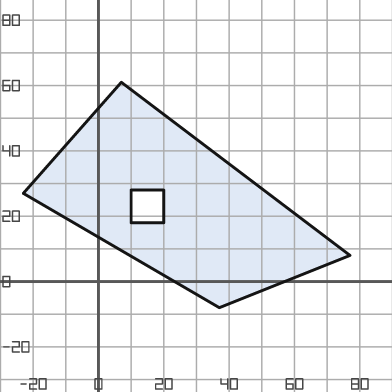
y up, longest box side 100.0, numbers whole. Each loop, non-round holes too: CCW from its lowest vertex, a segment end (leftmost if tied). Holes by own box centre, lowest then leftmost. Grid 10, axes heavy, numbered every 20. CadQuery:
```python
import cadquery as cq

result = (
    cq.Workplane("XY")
    .moveTo(37.0, -8.0)
    .lineTo(77.0, 8.0)
    .lineTo(7.0, 61.0)
    .lineTo(-23.0, 27.0)
    .close()
    .moveTo(10.0, 18.0)
    .lineTo(20.0, 18.0)
    .lineTo(20.0, 28.0)
    .lineTo(10.0, 28.0)
    .close()
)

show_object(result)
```